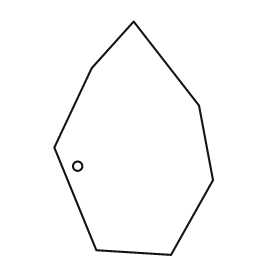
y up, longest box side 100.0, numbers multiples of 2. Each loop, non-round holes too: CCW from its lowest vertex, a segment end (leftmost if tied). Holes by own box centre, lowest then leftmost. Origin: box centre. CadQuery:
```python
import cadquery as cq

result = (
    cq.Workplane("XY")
    .moveTo(16.0, -50.0)
    .lineTo(34.0, -18.0)
    .lineTo(28.0, 14.0)
    .lineTo(0.0, 50.0)
    .lineTo(-18.0, 30.0)
    .lineTo(-34.0, -4.0)
    .lineTo(-16.0, -48.0)
    .close()
    .moveTo(-24.0, -12.0)
    .circle(2.0)
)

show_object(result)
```